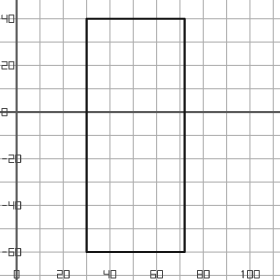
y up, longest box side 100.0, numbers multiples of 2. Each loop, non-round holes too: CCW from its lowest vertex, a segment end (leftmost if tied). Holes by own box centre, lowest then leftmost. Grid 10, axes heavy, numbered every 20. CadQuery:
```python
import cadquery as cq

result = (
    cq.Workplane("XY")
    .moveTo(30.0, -60.0)
    .lineTo(72.0, -60.0)
    .lineTo(72.0, 40.0)
    .lineTo(30.0, 40.0)
    .close()
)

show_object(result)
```